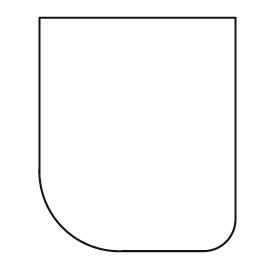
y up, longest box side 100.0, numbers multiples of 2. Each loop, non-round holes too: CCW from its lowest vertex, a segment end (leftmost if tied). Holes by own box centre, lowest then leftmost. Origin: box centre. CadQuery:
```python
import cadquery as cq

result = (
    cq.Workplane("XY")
    .moveTo(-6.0, -50.0)
    .lineTo(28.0, -50.0)
    .threePointArc((38.0, -46.0), (42.0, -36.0))
    .lineTo(42.0, 50.0)
    .lineTo(-42.0, 50.0)
    .lineTo(-42.0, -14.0)
    .threePointArc((-32.0, -40.0), (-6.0, -50.0))
    .close()
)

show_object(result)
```